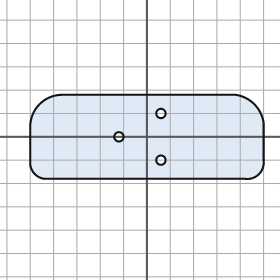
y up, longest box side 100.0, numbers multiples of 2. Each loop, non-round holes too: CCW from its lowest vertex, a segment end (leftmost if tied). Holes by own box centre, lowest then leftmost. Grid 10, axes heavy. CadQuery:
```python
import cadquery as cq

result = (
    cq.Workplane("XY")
    .moveTo(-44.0, -18.0)
    .lineTo(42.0, -18.0)
    .threePointArc((48.0, -16.0), (50.0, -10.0))
    .lineTo(50.0, 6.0)
    .threePointArc((46.0, 14.0), (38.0, 18.0))
    .lineTo(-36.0, 18.0)
    .threePointArc((-46.0, 14.0), (-50.0, 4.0))
    .lineTo(-50.0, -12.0)
    .threePointArc((-48.0, -16.0), (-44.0, -18.0))
    .close()
    .moveTo(6.0, -10.0)
    .circle(2.0)
    .moveTo(-12.0, 0.0)
    .circle(2.0)
    .moveTo(6.0, 10.0)
    .circle(2.0)
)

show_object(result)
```